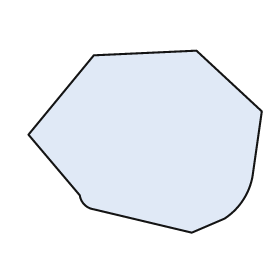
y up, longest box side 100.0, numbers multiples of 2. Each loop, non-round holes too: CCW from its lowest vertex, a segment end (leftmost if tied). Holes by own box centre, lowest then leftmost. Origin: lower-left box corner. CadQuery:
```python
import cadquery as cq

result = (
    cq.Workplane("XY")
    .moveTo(70.0, 0.0)
    .lineTo(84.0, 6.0)
    .threePointArc((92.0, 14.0), (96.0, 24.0))
    .lineTo(100.0, 52.0)
    .lineTo(72.0, 78.0)
    .lineTo(28.0, 76.0)
    .lineTo(0.0, 42.0)
    .lineTo(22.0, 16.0)
    .threePointArc((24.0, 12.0), (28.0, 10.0))
    .close()
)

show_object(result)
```